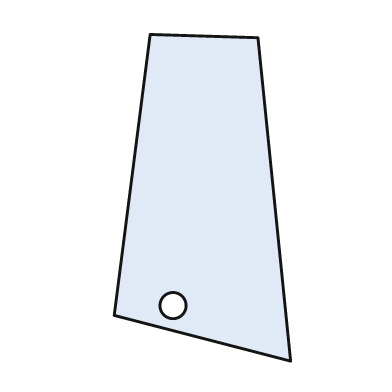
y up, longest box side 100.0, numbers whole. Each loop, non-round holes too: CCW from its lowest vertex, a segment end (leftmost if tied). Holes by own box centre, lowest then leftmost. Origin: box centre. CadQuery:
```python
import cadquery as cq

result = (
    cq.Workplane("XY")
    .moveTo(27.0, -50.0)
    .lineTo(17.0, 49.0)
    .lineTo(-16.0, 50.0)
    .lineTo(-27.0, -36.0)
    .close()
    .moveTo(-9.0, -33.0)
    .circle(4.0)
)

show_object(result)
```